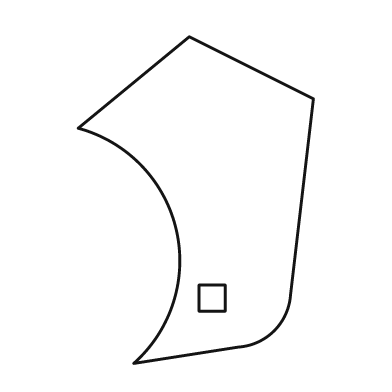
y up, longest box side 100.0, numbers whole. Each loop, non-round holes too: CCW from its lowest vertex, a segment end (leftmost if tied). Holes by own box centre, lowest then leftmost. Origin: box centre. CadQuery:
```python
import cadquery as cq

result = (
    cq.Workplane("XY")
    .moveTo(-19.0, -50.0)
    .lineTo(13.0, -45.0)
    .threePointArc((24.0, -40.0), (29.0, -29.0))
    .lineTo(36.0, 31.0)
    .lineTo(-2.0, 50.0)
    .lineTo(-36.0, 22.0)
    .threePointArc((-6.0, -9.0), (-19.0, -50.0))
    .close()
    .moveTo(1.0, -34.0)
    .lineTo(9.0, -34.0)
    .lineTo(9.0, -26.0)
    .lineTo(1.0, -26.0)
    .close()
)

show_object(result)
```